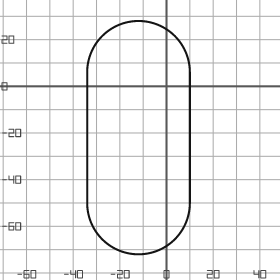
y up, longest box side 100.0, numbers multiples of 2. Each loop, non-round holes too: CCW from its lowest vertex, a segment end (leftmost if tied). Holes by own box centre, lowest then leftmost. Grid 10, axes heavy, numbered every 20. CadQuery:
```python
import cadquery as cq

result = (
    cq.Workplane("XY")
    .moveTo(-34.0, -50.0)
    .threePointArc((-12.0, -72.0), (10.0, -50.0))
    .lineTo(10.0, 6.0)
    .threePointArc((-12.0, 28.0), (-34.0, 6.0))
    .close()
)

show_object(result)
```